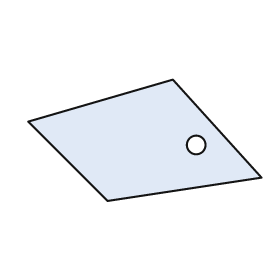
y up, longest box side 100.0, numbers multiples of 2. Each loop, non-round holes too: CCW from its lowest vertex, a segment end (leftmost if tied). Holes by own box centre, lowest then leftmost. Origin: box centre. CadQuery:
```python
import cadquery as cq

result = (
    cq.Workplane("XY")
    .moveTo(-16.0, -26.0)
    .lineTo(50.0, -16.0)
    .lineTo(12.0, 26.0)
    .lineTo(-50.0, 8.0)
    .close()
    .moveTo(22.0, -2.0)
    .circle(4.0)
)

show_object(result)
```